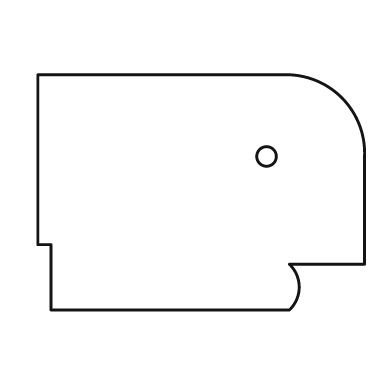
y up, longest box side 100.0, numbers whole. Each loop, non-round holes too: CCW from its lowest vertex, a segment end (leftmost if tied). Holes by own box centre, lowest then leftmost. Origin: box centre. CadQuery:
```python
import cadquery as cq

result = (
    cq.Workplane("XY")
    .moveTo(-46.0, -36.0)
    .lineTo(27.0, -36.0)
    .threePointArc((30.0, -29.0), (27.0, -22.0))
    .lineTo(50.0, -22.0)
    .lineTo(50.0, 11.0)
    .threePointArc((43.0, 29.0), (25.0, 36.0))
    .lineTo(-50.0, 36.0)
    .lineTo(-50.0, -16.0)
    .lineTo(-46.0, -16.0)
    .close()
    .moveTo(20.0, 11.0)
    .circle(3.0)
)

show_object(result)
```